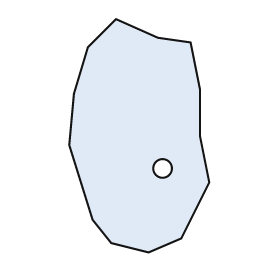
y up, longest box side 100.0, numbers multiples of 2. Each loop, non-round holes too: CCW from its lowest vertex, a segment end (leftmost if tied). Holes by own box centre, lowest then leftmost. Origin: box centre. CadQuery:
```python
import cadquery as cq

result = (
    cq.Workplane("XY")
    .moveTo(4.0, -50.0)
    .lineTo(18.0, -44.0)
    .lineTo(30.0, -20.0)
    .lineTo(26.0, 0.0)
    .lineTo(26.0, 20.0)
    .lineTo(22.0, 40.0)
    .lineTo(8.0, 42.0)
    .lineTo(-10.0, 50.0)
    .lineTo(-22.0, 38.0)
    .lineTo(-28.0, 18.0)
    .lineTo(-30.0, -4.0)
    .lineTo(-20.0, -36.0)
    .lineTo(-12.0, -46.0)
    .close()
    .moveTo(10.0, -14.0)
    .circle(4.0)
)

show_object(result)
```